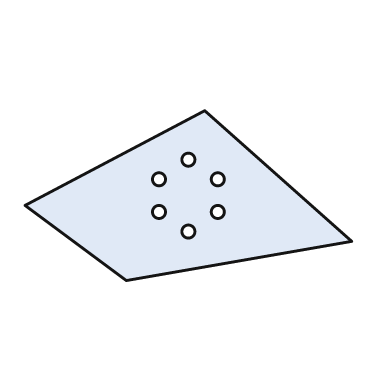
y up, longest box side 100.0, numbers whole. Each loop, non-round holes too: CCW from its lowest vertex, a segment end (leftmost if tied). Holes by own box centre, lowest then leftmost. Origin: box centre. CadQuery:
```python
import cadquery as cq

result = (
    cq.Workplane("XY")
    .moveTo(-19.0, -26.0)
    .lineTo(50.0, -14.0)
    .lineTo(5.0, 26.0)
    .lineTo(-50.0, -3.0)
    .close()
    .moveTo(0.0, -11.0)
    .circle(2.0)
    .moveTo(-9.0, -5.0)
    .circle(2.0)
    .moveTo(9.0, -5.0)
    .circle(2.0)
    .moveTo(-9.0, 5.0)
    .circle(2.0)
    .moveTo(9.0, 5.0)
    .circle(2.0)
    .moveTo(0.0, 11.0)
    .circle(2.0)
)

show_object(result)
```